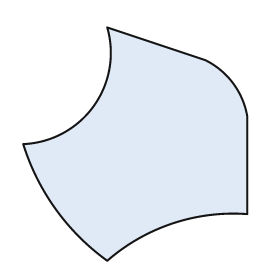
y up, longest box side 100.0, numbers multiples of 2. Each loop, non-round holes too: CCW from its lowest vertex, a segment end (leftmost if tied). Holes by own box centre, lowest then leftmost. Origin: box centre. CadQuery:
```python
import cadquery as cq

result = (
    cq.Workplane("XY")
    .moveTo(-12.0, -50.0)
    .threePointArc((16.0, -34.0), (48.0, -30.0))
    .lineTo(48.0, 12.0)
    .threePointArc((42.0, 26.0), (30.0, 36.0))
    .lineTo(-12.0, 50.0)
    .threePointArc((-18.0, 16.0), (-48.0, 0.0))
    .threePointArc((-34.0, -28.0), (-12.0, -50.0))
    .close()
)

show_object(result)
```